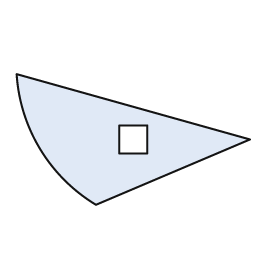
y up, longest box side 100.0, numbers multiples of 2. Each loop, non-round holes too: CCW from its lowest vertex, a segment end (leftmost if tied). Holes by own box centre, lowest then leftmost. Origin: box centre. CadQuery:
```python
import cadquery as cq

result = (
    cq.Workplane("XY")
    .moveTo(-16.0, -28.0)
    .lineTo(50.0, 0.0)
    .lineTo(-50.0, 28.0)
    .threePointArc((-40.0, -4.0), (-16.0, -28.0))
    .close()
    .moveTo(-6.0, -6.0)
    .lineTo(6.0, -6.0)
    .lineTo(6.0, 6.0)
    .lineTo(-6.0, 6.0)
    .close()
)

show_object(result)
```